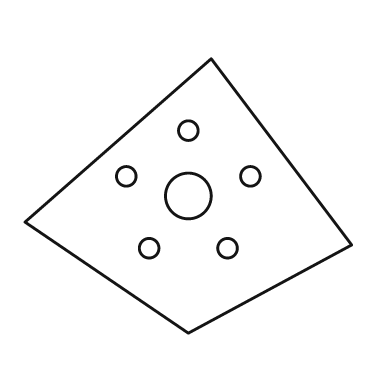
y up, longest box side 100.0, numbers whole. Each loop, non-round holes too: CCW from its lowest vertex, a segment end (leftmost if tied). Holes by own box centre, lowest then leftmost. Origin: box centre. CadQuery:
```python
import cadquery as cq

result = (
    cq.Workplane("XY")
    .moveTo(0.0, -42.0)
    .lineTo(50.0, -15.0)
    .lineTo(7.0, 42.0)
    .lineTo(-50.0, -8.0)
    .close()
    .moveTo(-12.0, -16.0)
    .circle(3.0)
    .moveTo(12.0, -16.0)
    .circle(3.0)
    .moveTo(0.0, 0.0)
    .circle(7.0)
    .moveTo(-19.0, 6.0)
    .circle(3.0)
    .moveTo(19.0, 6.0)
    .circle(3.0)
    .moveTo(0.0, 20.0)
    .circle(3.0)
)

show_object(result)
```